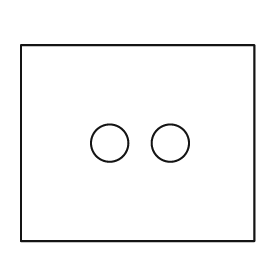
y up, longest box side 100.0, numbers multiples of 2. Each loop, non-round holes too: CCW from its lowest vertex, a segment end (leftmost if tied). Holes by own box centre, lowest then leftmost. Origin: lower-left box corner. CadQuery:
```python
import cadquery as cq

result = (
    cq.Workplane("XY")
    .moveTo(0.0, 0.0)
    .lineTo(100.0, 0.0)
    .lineTo(100.0, 84.0)
    .lineTo(0.0, 84.0)
    .close()
    .moveTo(38.0, 42.0)
    .circle(8.0)
    .moveTo(64.0, 42.0)
    .circle(8.0)
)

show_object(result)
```